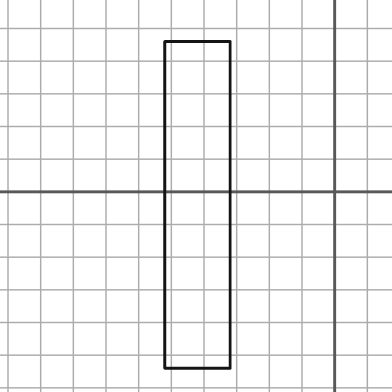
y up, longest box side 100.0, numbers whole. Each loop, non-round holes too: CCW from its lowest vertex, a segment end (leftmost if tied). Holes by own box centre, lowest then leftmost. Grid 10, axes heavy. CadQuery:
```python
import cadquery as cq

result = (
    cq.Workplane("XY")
    .moveTo(-52.0, -54.0)
    .lineTo(-32.0, -54.0)
    .lineTo(-32.0, 46.0)
    .lineTo(-52.0, 46.0)
    .close()
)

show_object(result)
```